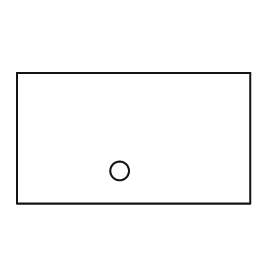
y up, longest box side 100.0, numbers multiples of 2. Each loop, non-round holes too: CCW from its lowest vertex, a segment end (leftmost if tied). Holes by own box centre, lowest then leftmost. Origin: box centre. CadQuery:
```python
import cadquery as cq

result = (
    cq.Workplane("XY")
    .moveTo(-50.0, -28.0)
    .lineTo(50.0, -28.0)
    .lineTo(50.0, 28.0)
    .lineTo(-50.0, 28.0)
    .close()
    .moveTo(-6.0, -14.0)
    .circle(4.0)
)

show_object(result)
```